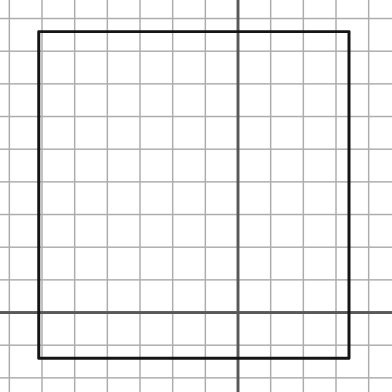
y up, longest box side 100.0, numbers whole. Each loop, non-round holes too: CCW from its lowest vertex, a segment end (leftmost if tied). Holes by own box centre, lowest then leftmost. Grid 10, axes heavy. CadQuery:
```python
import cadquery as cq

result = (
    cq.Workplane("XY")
    .moveTo(-61.0, -14.0)
    .lineTo(34.0, -14.0)
    .lineTo(34.0, 86.0)
    .lineTo(-61.0, 86.0)
    .close()
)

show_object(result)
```